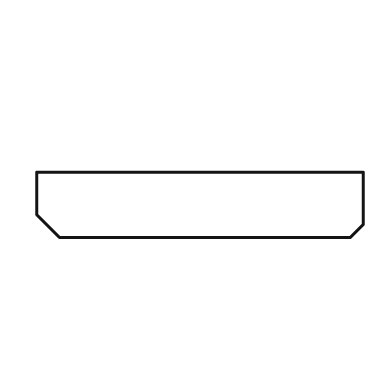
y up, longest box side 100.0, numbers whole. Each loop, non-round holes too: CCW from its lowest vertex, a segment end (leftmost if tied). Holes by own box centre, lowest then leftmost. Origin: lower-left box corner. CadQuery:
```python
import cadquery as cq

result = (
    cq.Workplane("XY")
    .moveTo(7.0, 0.0)
    .lineTo(96.0, 0.0)
    .lineTo(100.0, 4.0)
    .lineTo(100.0, 20.0)
    .lineTo(0.0, 20.0)
    .lineTo(0.0, 7.0)
    .close()
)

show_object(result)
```